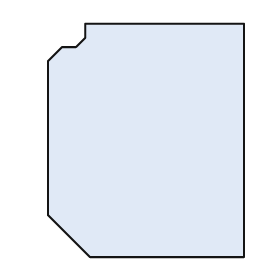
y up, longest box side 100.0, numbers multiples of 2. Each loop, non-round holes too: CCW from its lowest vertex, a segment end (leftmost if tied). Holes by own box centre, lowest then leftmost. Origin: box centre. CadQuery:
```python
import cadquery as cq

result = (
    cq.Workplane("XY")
    .moveTo(-24.0, -50.0)
    .lineTo(42.0, -50.0)
    .lineTo(42.0, 50.0)
    .lineTo(-26.0, 50.0)
    .lineTo(-26.0, 44.0)
    .lineTo(-30.0, 40.0)
    .lineTo(-36.0, 40.0)
    .lineTo(-42.0, 34.0)
    .lineTo(-42.0, -32.0)
    .close()
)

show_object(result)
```